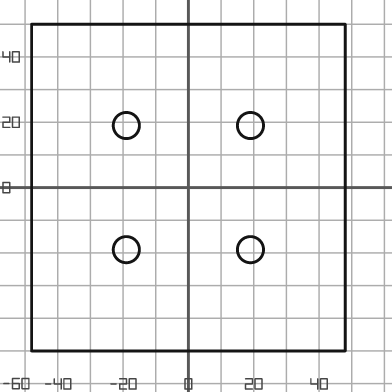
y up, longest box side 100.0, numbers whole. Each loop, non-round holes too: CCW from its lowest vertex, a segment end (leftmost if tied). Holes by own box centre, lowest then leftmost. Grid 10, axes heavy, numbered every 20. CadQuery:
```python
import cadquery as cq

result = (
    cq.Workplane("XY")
    .moveTo(-48.0, -50.0)
    .lineTo(48.0, -50.0)
    .lineTo(48.0, 50.0)
    .lineTo(-48.0, 50.0)
    .close()
    .moveTo(-19.0, -19.0)
    .circle(4.0)
    .moveTo(19.0, -19.0)
    .circle(4.0)
    .moveTo(-19.0, 19.0)
    .circle(4.0)
    .moveTo(19.0, 19.0)
    .circle(4.0)
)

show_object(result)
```